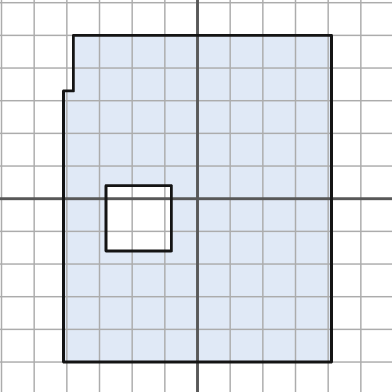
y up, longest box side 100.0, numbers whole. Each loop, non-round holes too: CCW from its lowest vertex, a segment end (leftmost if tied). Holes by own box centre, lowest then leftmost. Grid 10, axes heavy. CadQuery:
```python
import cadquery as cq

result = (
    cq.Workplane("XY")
    .moveTo(-41.0, -50.0)
    .lineTo(41.0, -50.0)
    .lineTo(41.0, 50.0)
    .lineTo(-38.0, 50.0)
    .lineTo(-38.0, 33.0)
    .lineTo(-41.0, 33.0)
    .close()
    .moveTo(-28.0, -16.0)
    .lineTo(-8.0, -16.0)
    .lineTo(-8.0, 4.0)
    .lineTo(-28.0, 4.0)
    .close()
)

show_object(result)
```